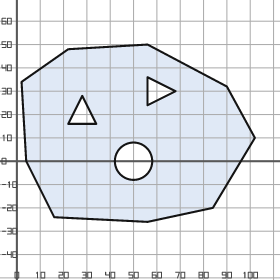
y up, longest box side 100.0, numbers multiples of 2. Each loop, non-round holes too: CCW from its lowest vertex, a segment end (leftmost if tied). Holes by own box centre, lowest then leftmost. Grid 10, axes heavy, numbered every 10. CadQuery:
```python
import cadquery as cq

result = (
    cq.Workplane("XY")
    .moveTo(56.0, -26.0)
    .lineTo(84.0, -20.0)
    .lineTo(102.0, 10.0)
    .lineTo(90.0, 32.0)
    .lineTo(56.0, 50.0)
    .lineTo(22.0, 48.0)
    .lineTo(2.0, 34.0)
    .lineTo(4.0, 0.0)
    .lineTo(16.0, -24.0)
    .close()
    .moveTo(50.0, 0.0)
    .circle(8.0)
    .moveTo(22.0, 16.0)
    .lineTo(34.0, 16.0)
    .lineTo(28.0, 28.0)
    .close()
    .moveTo(56.0, 24.0)
    .lineTo(68.0, 30.0)
    .lineTo(56.0, 36.0)
    .close()
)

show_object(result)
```